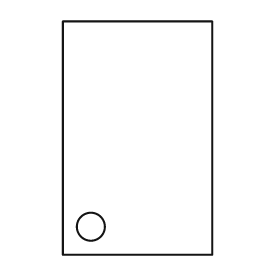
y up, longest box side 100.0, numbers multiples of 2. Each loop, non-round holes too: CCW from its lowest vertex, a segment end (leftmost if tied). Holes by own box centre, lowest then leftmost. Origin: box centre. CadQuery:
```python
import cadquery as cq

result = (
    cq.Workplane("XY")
    .moveTo(-32.0, -50.0)
    .lineTo(32.0, -50.0)
    .lineTo(32.0, 50.0)
    .lineTo(-32.0, 50.0)
    .close()
    .moveTo(-20.0, -38.0)
    .circle(6.0)
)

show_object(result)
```